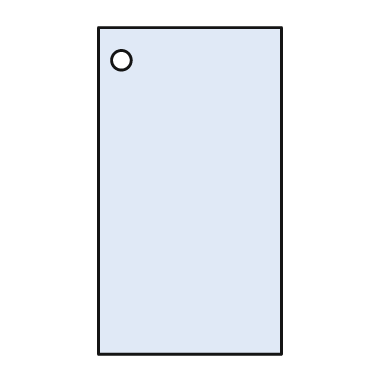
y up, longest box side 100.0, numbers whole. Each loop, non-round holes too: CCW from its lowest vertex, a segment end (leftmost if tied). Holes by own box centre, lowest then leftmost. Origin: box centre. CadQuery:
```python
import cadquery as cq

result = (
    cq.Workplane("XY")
    .moveTo(-28.0, -50.0)
    .lineTo(28.0, -50.0)
    .lineTo(28.0, 50.0)
    .lineTo(-28.0, 50.0)
    .close()
    .moveTo(-21.0, 40.0)
    .circle(3.0)
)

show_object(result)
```